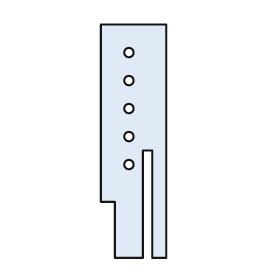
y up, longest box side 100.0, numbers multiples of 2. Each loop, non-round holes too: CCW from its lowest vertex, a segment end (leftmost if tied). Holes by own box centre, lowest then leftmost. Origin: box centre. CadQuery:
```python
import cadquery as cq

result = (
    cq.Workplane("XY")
    .moveTo(-8.0, -50.0)
    .lineTo(4.0, -50.0)
    .lineTo(4.0, -4.0)
    .lineTo(8.0, -4.0)
    .lineTo(8.0, -50.0)
    .lineTo(14.0, -50.0)
    .lineTo(14.0, 50.0)
    .lineTo(-14.0, 50.0)
    .lineTo(-14.0, -26.0)
    .lineTo(-8.0, -26.0)
    .close()
    .moveTo(-2.0, -10.0)
    .circle(2.0)
    .moveTo(-2.0, 2.0)
    .circle(2.0)
    .moveTo(-2.0, 14.0)
    .circle(2.0)
    .moveTo(-2.0, 26.0)
    .circle(2.0)
    .moveTo(-2.0, 38.0)
    .circle(2.0)
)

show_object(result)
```